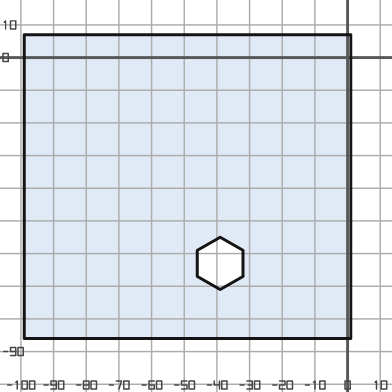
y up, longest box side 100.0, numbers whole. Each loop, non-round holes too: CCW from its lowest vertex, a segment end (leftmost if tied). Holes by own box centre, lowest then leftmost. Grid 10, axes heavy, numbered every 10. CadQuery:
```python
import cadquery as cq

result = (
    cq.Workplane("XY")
    .moveTo(-99.0, -86.0)
    .lineTo(1.0, -86.0)
    .lineTo(1.0, 7.0)
    .lineTo(-99.0, 7.0)
    .close()
    .moveTo(-39.0, -71.0)
    .lineTo(-32.0, -67.0)
    .lineTo(-32.0, -59.0)
    .lineTo(-39.0, -55.0)
    .lineTo(-46.0, -59.0)
    .lineTo(-46.0, -67.0)
    .close()
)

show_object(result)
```